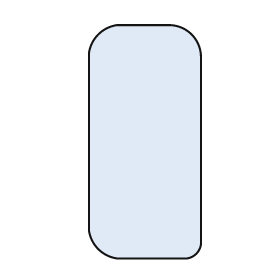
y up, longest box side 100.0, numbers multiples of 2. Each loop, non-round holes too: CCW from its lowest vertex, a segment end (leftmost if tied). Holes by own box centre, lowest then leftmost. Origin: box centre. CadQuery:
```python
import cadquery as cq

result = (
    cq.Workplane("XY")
    .moveTo(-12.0, -50.0)
    .lineTo(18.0, -50.0)
    .threePointArc((22.0, -48.0), (24.0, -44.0))
    .lineTo(24.0, 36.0)
    .threePointArc((20.0, 46.0), (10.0, 50.0))
    .lineTo(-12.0, 50.0)
    .threePointArc((-20.0, 46.0), (-24.0, 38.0))
    .lineTo(-24.0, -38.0)
    .threePointArc((-20.0, -46.0), (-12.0, -50.0))
    .close()
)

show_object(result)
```